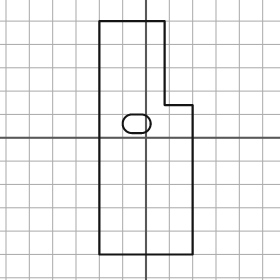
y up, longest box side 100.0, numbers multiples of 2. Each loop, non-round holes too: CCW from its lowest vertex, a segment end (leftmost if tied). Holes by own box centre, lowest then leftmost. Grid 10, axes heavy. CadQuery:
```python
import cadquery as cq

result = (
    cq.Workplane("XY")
    .moveTo(-20.0, -50.0)
    .lineTo(20.0, -50.0)
    .lineTo(20.0, 14.0)
    .lineTo(8.0, 14.0)
    .lineTo(8.0, 50.0)
    .lineTo(-20.0, 50.0)
    .close()
    .moveTo(-6.0, 2.0)
    .lineTo(-2.0, 2.0)
    .threePointArc((2.0, 6.0), (-2.0, 10.0))
    .lineTo(-6.0, 10.0)
    .threePointArc((-10.0, 6.0), (-6.0, 2.0))
    .close()
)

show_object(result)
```